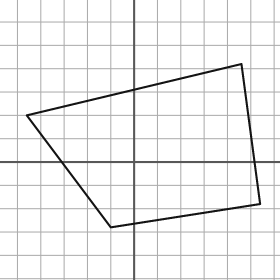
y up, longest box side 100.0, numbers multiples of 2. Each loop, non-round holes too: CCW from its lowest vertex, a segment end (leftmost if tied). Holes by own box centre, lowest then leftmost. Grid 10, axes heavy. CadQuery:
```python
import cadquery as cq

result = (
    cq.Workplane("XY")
    .moveTo(-10.0, -28.0)
    .lineTo(54.0, -18.0)
    .lineTo(46.0, 42.0)
    .lineTo(-46.0, 20.0)
    .close()
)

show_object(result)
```